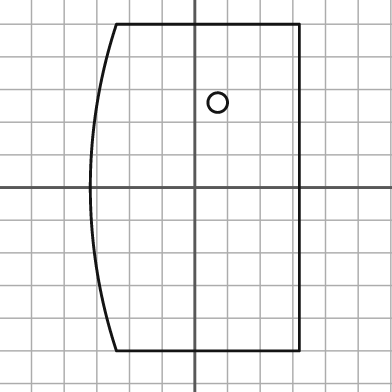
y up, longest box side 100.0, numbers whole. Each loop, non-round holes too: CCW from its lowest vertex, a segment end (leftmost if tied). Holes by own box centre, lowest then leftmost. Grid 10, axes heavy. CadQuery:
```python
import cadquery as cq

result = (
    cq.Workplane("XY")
    .moveTo(-24.0, -50.0)
    .lineTo(32.0, -50.0)
    .lineTo(32.0, 50.0)
    .lineTo(-24.0, 50.0)
    .threePointArc((-32.0, 0.0), (-24.0, -50.0))
    .close()
    .moveTo(7.0, 26.0)
    .circle(3.0)
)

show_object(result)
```